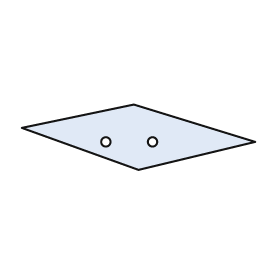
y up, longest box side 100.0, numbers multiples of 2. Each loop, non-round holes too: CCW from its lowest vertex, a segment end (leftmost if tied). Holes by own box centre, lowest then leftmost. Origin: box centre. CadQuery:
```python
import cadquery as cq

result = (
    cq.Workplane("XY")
    .moveTo(0.0, -14.0)
    .lineTo(50.0, -2.0)
    .lineTo(-2.0, 14.0)
    .lineTo(-50.0, 4.0)
    .close()
    .moveTo(-14.0, -2.0)
    .circle(2.0)
    .moveTo(6.0, -2.0)
    .circle(2.0)
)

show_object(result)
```